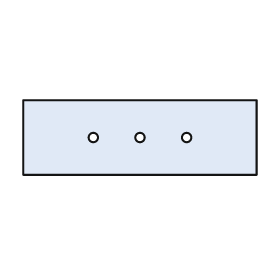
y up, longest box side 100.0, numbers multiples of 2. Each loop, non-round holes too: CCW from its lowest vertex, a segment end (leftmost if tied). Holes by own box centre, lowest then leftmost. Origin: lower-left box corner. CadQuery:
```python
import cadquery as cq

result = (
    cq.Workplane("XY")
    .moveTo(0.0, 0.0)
    .lineTo(100.0, 0.0)
    .lineTo(100.0, 32.0)
    .lineTo(0.0, 32.0)
    .close()
    .moveTo(30.0, 16.0)
    .circle(2.0)
    .moveTo(50.0, 16.0)
    .circle(2.0)
    .moveTo(70.0, 16.0)
    .circle(2.0)
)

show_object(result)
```